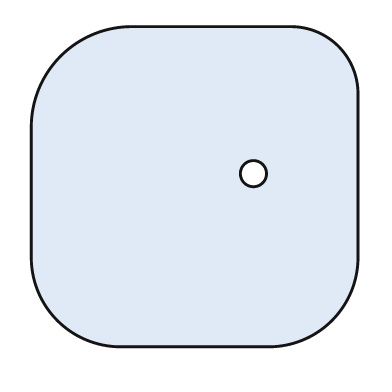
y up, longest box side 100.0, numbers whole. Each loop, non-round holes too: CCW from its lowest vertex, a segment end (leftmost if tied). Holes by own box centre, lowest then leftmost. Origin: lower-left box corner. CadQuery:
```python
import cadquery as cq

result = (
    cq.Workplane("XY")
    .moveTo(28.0, 0.0)
    .lineTo(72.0, 0.0)
    .threePointArc((92.0, 8.0), (100.0, 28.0))
    .lineTo(100.0, 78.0)
    .threePointArc((94.0, 92.0), (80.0, 98.0))
    .lineTo(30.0, 98.0)
    .threePointArc((9.0, 89.0), (0.0, 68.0))
    .lineTo(0.0, 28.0)
    .threePointArc((8.0, 8.0), (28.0, 0.0))
    .close()
    .moveTo(68.0, 53.0)
    .circle(4.0)
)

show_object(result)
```